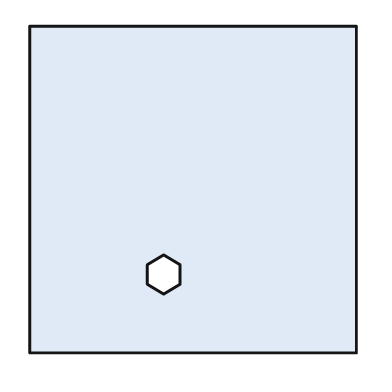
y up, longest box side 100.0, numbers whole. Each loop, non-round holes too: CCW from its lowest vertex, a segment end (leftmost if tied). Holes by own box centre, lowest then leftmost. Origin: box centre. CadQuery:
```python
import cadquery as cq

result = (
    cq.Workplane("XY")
    .moveTo(-50.0, -50.0)
    .lineTo(50.0, -50.0)
    .lineTo(50.0, 50.0)
    .lineTo(-50.0, 50.0)
    .close()
    .moveTo(-9.0, -32.0)
    .lineTo(-4.0, -29.0)
    .lineTo(-4.0, -23.0)
    .lineTo(-9.0, -20.0)
    .lineTo(-14.0, -23.0)
    .lineTo(-14.0, -29.0)
    .close()
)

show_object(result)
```